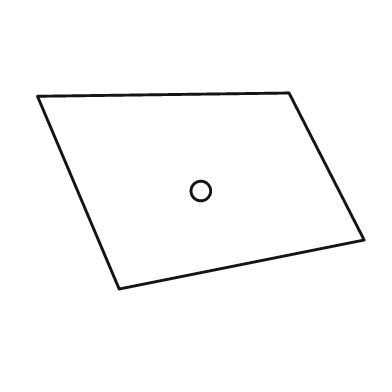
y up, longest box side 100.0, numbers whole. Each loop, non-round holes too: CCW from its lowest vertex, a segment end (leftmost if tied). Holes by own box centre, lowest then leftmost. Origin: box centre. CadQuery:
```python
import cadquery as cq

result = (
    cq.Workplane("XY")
    .moveTo(-25.0, -30.0)
    .lineTo(50.0, -15.0)
    .lineTo(27.0, 30.0)
    .lineTo(-50.0, 29.0)
    .close()
    .moveTo(0.0, 0.0)
    .circle(3.0)
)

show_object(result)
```